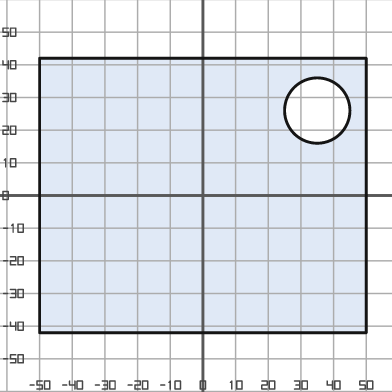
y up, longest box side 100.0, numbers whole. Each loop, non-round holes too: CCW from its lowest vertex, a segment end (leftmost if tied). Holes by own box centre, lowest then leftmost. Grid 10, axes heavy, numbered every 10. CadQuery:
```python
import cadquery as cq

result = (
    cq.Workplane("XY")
    .moveTo(-50.0, -42.0)
    .lineTo(50.0, -42.0)
    .lineTo(50.0, 42.0)
    .lineTo(-50.0, 42.0)
    .close()
    .moveTo(35.0, 26.0)
    .circle(10.0)
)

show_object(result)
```